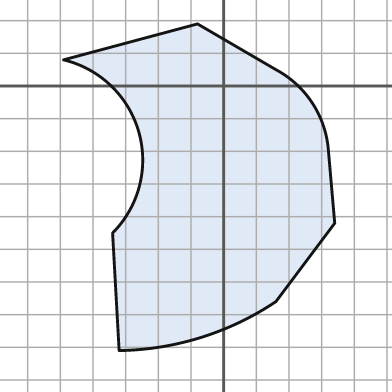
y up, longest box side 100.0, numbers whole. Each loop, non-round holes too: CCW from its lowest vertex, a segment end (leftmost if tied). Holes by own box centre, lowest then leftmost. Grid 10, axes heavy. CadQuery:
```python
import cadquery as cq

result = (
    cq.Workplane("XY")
    .moveTo(-32.0, -81.0)
    .threePointArc((-7.0, -77.0), (16.0, -66.0))
    .lineTo(34.0, -42.0)
    .lineTo(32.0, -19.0)
    .threePointArc((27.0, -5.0), (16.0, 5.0))
    .lineTo(-8.0, 19.0)
    .lineTo(-49.0, 8.0)
    .threePointArc((-26.0, -14.0), (-34.0, -45.0))
    .close()
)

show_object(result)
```